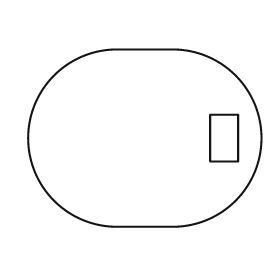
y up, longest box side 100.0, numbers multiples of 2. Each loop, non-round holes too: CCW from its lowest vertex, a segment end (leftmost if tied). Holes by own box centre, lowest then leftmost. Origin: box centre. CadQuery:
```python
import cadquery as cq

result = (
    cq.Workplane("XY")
    .moveTo(-12.0, -38.0)
    .lineTo(12.0, -38.0)
    .threePointArc((50.0, 0.0), (12.0, 38.0))
    .lineTo(-12.0, 38.0)
    .threePointArc((-50.0, 0.0), (-12.0, -38.0))
    .close()
    .moveTo(28.0, -10.0)
    .lineTo(40.0, -10.0)
    .lineTo(40.0, 10.0)
    .lineTo(28.0, 10.0)
    .close()
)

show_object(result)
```